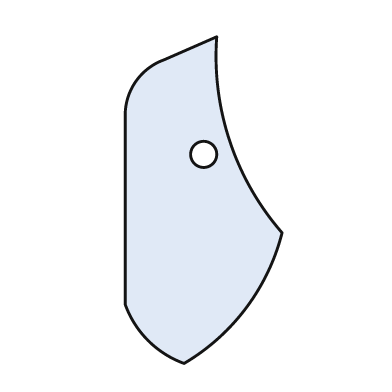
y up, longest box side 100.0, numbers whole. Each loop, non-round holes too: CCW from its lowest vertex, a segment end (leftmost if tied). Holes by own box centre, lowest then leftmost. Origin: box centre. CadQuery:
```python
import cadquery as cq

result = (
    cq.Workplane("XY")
    .moveTo(-6.0, -50.0)
    .threePointArc((13.0, -33.0), (24.0, -10.0))
    .threePointArc((8.0, 18.0), (4.0, 50.0))
    .lineTo(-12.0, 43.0)
    .threePointArc((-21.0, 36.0), (-24.0, 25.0))
    .lineTo(-24.0, -32.0)
    .threePointArc((-17.0, -43.0), (-6.0, -50.0))
    .close()
    .moveTo(0.0, 14.0)
    .circle(4.0)
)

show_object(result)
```